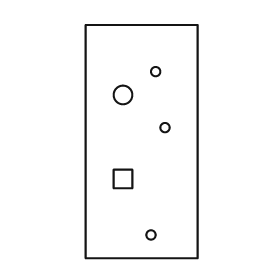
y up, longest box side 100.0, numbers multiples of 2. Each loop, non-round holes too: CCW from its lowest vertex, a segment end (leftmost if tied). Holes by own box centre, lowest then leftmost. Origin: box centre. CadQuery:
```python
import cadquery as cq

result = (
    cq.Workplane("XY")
    .moveTo(-24.0, -50.0)
    .lineTo(24.0, -50.0)
    .lineTo(24.0, 50.0)
    .lineTo(-24.0, 50.0)
    .close()
    .moveTo(4.0, -40.0)
    .circle(2.0)
    .moveTo(-12.0, -20.0)
    .lineTo(-4.0, -20.0)
    .lineTo(-4.0, -12.0)
    .lineTo(-12.0, -12.0)
    .close()
    .moveTo(10.0, 6.0)
    .circle(2.0)
    .moveTo(-8.0, 20.0)
    .circle(4.0)
    .moveTo(6.0, 30.0)
    .circle(2.0)
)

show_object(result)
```